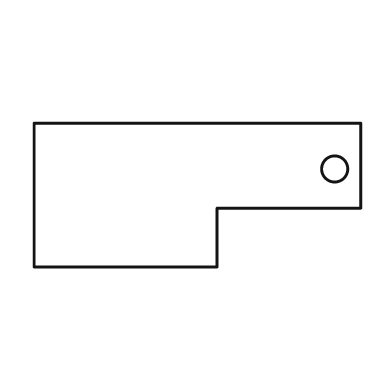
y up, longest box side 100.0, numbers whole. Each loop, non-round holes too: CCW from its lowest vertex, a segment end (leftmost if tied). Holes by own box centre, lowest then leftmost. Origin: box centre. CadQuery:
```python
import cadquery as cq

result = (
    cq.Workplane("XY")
    .moveTo(-50.0, -22.0)
    .lineTo(6.0, -22.0)
    .lineTo(6.0, -4.0)
    .lineTo(50.0, -4.0)
    .lineTo(50.0, 22.0)
    .lineTo(-50.0, 22.0)
    .close()
    .moveTo(42.0, 8.0)
    .circle(4.0)
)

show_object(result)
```